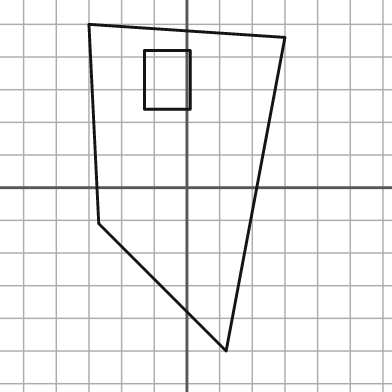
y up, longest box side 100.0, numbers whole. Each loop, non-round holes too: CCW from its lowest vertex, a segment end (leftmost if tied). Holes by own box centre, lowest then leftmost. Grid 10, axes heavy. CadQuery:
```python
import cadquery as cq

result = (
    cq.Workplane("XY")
    .moveTo(12.0, -50.0)
    .lineTo(30.0, 46.0)
    .lineTo(-30.0, 50.0)
    .lineTo(-27.0, -11.0)
    .close()
    .moveTo(-13.0, 24.0)
    .lineTo(1.0, 24.0)
    .lineTo(1.0, 42.0)
    .lineTo(-13.0, 42.0)
    .close()
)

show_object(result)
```